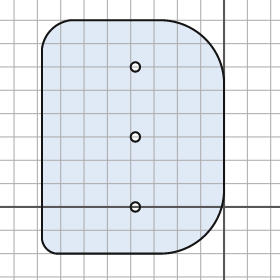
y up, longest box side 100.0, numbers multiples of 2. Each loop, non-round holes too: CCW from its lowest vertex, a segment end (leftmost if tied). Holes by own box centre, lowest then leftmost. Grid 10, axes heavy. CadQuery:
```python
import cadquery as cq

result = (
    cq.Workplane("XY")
    .moveTo(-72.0, -20.0)
    .lineTo(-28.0, -20.0)
    .threePointArc((-8.0, -12.0), (0.0, 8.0))
    .lineTo(0.0, 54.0)
    .threePointArc((-8.0, 72.0), (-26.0, 80.0))
    .lineTo(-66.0, 80.0)
    .threePointArc((-74.0, 76.0), (-78.0, 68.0))
    .lineTo(-78.0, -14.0)
    .threePointArc((-76.0, -18.0), (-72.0, -20.0))
    .close()
    .moveTo(-38.0, 0.0)
    .circle(2.0)
    .moveTo(-38.0, 30.0)
    .circle(2.0)
    .moveTo(-38.0, 60.0)
    .circle(2.0)
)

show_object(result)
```